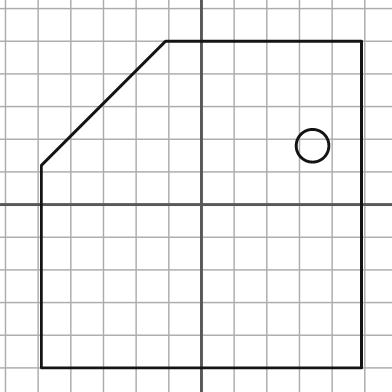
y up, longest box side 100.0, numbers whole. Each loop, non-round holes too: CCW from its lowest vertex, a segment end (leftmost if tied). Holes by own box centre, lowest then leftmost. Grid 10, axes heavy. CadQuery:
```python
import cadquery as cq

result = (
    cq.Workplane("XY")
    .moveTo(-49.0, -50.0)
    .lineTo(49.0, -50.0)
    .lineTo(49.0, 50.0)
    .lineTo(-11.0, 50.0)
    .lineTo(-49.0, 12.0)
    .close()
    .moveTo(34.0, 18.0)
    .circle(5.0)
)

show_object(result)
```